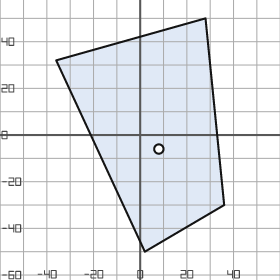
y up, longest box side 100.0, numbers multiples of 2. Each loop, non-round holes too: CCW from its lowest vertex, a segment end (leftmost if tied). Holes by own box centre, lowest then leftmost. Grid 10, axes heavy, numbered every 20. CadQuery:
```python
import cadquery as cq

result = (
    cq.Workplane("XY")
    .moveTo(2.0, -50.0)
    .lineTo(36.0, -30.0)
    .lineTo(28.0, 50.0)
    .lineTo(-36.0, 32.0)
    .close()
    .moveTo(8.0, -6.0)
    .circle(2.0)
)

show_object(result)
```